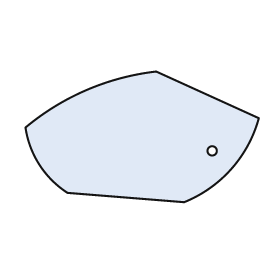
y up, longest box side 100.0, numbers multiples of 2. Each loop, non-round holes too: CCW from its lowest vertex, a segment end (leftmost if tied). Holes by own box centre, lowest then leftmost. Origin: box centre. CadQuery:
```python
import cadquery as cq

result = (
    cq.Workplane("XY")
    .moveTo(18.0, -28.0)
    .threePointArc((38.0, -14.0), (50.0, 8.0))
    .lineTo(6.0, 28.0)
    .threePointArc((-24.0, 20.0), (-50.0, 4.0))
    .threePointArc((-44.0, -12.0), (-32.0, -24.0))
    .close()
    .moveTo(30.0, -6.0)
    .circle(2.0)
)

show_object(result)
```